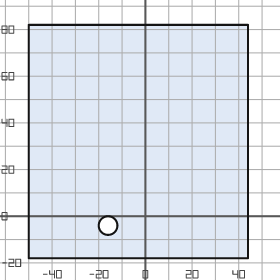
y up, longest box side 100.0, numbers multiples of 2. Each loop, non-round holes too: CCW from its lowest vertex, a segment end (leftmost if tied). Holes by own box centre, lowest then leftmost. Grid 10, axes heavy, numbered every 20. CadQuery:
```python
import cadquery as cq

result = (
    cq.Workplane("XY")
    .moveTo(-50.0, -18.0)
    .lineTo(44.0, -18.0)
    .lineTo(44.0, 82.0)
    .lineTo(-50.0, 82.0)
    .close()
    .moveTo(-16.0, -4.0)
    .circle(4.0)
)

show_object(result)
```